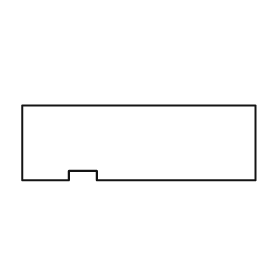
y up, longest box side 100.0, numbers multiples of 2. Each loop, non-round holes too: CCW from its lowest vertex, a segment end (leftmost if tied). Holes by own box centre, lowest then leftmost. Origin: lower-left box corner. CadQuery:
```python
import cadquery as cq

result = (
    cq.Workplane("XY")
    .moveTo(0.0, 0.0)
    .lineTo(20.0, 0.0)
    .lineTo(20.0, 4.0)
    .lineTo(32.0, 4.0)
    .lineTo(32.0, 0.0)
    .lineTo(100.0, 0.0)
    .lineTo(100.0, 32.0)
    .lineTo(0.0, 32.0)
    .close()
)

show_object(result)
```